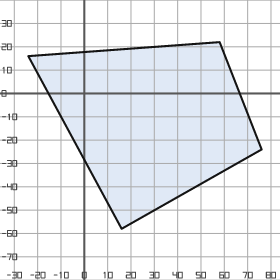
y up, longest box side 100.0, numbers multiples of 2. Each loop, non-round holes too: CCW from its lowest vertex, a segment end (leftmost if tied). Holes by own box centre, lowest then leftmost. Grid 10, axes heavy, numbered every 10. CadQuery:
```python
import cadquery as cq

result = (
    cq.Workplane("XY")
    .moveTo(16.0, -58.0)
    .lineTo(76.0, -24.0)
    .lineTo(58.0, 22.0)
    .lineTo(-24.0, 16.0)
    .close()
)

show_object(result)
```